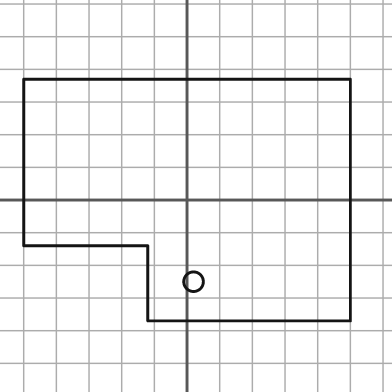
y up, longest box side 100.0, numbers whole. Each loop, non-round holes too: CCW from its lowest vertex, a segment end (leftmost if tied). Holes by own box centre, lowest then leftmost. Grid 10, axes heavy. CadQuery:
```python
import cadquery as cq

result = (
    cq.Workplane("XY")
    .moveTo(-12.0, -37.0)
    .lineTo(50.0, -37.0)
    .lineTo(50.0, 37.0)
    .lineTo(-50.0, 37.0)
    .lineTo(-50.0, -14.0)
    .lineTo(-12.0, -14.0)
    .close()
    .moveTo(2.0, -25.0)
    .circle(3.0)
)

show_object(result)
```